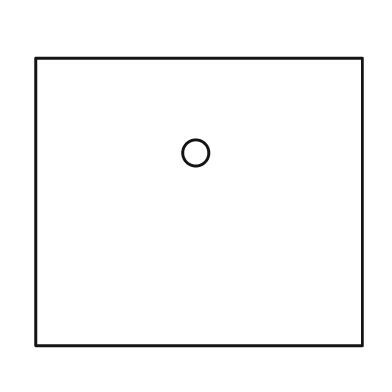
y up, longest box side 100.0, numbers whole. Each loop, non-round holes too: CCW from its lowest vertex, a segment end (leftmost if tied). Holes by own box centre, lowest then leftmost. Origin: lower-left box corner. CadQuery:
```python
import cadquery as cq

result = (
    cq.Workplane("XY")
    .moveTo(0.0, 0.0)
    .lineTo(100.0, 0.0)
    .lineTo(100.0, 88.0)
    .lineTo(0.0, 88.0)
    .close()
    .moveTo(49.0, 59.0)
    .circle(4.0)
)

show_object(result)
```